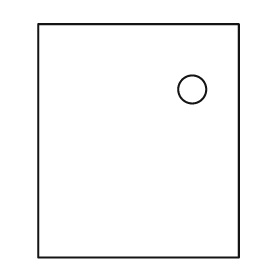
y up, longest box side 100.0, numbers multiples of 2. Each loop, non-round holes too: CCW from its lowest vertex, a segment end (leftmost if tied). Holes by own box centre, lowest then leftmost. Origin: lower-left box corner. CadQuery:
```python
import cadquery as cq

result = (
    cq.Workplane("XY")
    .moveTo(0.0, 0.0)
    .lineTo(86.0, 0.0)
    .lineTo(86.0, 100.0)
    .lineTo(0.0, 100.0)
    .close()
    .moveTo(66.0, 72.0)
    .circle(6.0)
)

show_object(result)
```